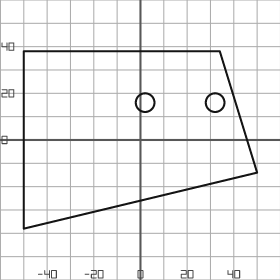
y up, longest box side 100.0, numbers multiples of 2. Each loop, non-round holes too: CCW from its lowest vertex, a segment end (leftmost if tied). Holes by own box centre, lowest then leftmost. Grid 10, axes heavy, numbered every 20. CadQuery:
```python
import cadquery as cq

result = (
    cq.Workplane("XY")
    .moveTo(-50.0, -38.0)
    .lineTo(50.0, -14.0)
    .lineTo(34.0, 38.0)
    .lineTo(-50.0, 38.0)
    .close()
    .moveTo(2.0, 16.0)
    .circle(4.0)
    .moveTo(32.0, 16.0)
    .circle(4.0)
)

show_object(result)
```